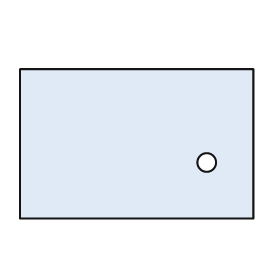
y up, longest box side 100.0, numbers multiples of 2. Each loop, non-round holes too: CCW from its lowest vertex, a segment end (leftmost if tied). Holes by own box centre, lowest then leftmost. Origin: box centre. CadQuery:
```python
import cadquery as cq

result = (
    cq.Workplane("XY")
    .moveTo(-50.0, -32.0)
    .lineTo(50.0, -32.0)
    .lineTo(50.0, 32.0)
    .lineTo(-50.0, 32.0)
    .close()
    .moveTo(30.0, -8.0)
    .circle(4.0)
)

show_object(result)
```